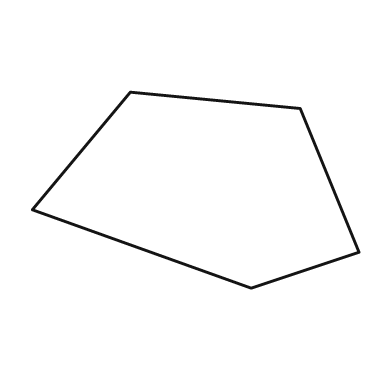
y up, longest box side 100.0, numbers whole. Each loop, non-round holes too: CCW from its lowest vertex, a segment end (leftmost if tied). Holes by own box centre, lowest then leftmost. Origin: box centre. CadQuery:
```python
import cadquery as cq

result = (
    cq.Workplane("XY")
    .moveTo(17.0, -30.0)
    .lineTo(50.0, -19.0)
    .lineTo(32.0, 25.0)
    .lineTo(-20.0, 30.0)
    .lineTo(-50.0, -6.0)
    .close()
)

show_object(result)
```